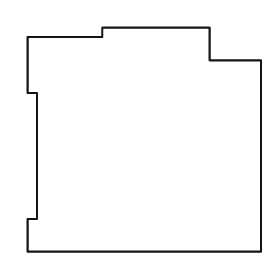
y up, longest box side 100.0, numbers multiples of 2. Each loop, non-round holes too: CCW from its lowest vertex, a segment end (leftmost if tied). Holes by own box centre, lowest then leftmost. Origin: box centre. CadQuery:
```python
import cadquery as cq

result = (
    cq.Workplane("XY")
    .moveTo(-50.0, -48.0)
    .lineTo(50.0, -48.0)
    .lineTo(50.0, 34.0)
    .lineTo(28.0, 34.0)
    .lineTo(28.0, 48.0)
    .lineTo(-18.0, 48.0)
    .lineTo(-18.0, 44.0)
    .lineTo(-50.0, 44.0)
    .lineTo(-50.0, 20.0)
    .lineTo(-46.0, 20.0)
    .lineTo(-46.0, -34.0)
    .lineTo(-50.0, -34.0)
    .close()
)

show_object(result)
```